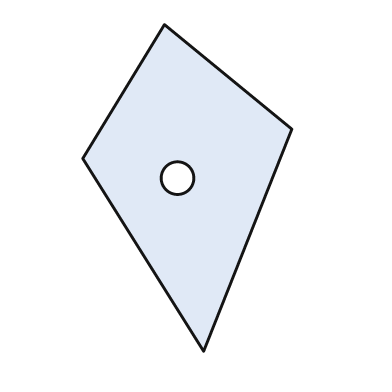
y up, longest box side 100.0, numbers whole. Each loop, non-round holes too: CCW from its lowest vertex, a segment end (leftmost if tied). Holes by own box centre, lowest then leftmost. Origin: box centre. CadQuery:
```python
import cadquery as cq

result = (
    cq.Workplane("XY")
    .moveTo(5.0, -50.0)
    .lineTo(32.0, 18.0)
    .lineTo(-7.0, 50.0)
    .lineTo(-32.0, 9.0)
    .close()
    .moveTo(-3.0, 3.0)
    .circle(5.0)
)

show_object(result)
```